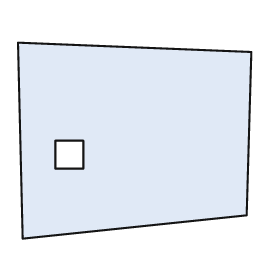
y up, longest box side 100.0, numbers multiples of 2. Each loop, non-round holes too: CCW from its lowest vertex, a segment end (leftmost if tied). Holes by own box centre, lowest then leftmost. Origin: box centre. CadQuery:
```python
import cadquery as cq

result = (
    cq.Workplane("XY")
    .moveTo(-48.0, -42.0)
    .lineTo(48.0, -32.0)
    .lineTo(50.0, 38.0)
    .lineTo(-50.0, 42.0)
    .close()
    .moveTo(-34.0, -12.0)
    .lineTo(-22.0, -12.0)
    .lineTo(-22.0, 0.0)
    .lineTo(-34.0, 0.0)
    .close()
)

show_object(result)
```